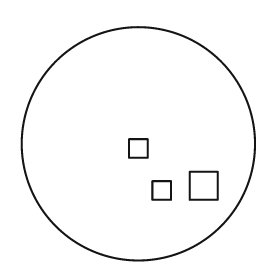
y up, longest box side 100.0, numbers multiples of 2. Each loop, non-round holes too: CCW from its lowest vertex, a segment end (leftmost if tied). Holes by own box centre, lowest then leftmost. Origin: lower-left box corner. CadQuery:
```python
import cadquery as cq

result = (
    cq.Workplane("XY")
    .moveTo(50.0, 50.0)
    .circle(50.0)
    .moveTo(56.0, 26.0)
    .lineTo(64.0, 26.0)
    .lineTo(64.0, 34.0)
    .lineTo(56.0, 34.0)
    .close()
    .moveTo(72.0, 26.0)
    .lineTo(84.0, 26.0)
    .lineTo(84.0, 38.0)
    .lineTo(72.0, 38.0)
    .close()
    .moveTo(46.0, 44.0)
    .lineTo(54.0, 44.0)
    .lineTo(54.0, 52.0)
    .lineTo(46.0, 52.0)
    .close()
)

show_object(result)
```